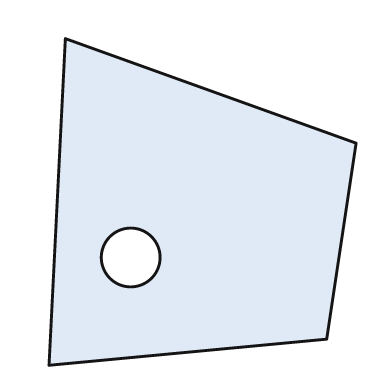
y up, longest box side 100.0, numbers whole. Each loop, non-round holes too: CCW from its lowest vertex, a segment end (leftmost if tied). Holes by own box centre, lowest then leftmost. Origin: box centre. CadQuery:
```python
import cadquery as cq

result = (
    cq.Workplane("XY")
    .moveTo(-47.0, -50.0)
    .lineTo(38.0, -42.0)
    .lineTo(47.0, 18.0)
    .lineTo(-42.0, 50.0)
    .close()
    .moveTo(-22.0, -17.0)
    .circle(9.0)
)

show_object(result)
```